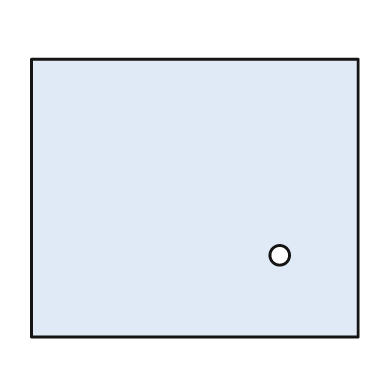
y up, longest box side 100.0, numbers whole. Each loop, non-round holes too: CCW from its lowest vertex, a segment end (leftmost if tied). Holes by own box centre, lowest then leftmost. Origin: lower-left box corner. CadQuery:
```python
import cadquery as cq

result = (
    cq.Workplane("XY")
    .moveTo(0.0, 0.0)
    .lineTo(100.0, 0.0)
    .lineTo(100.0, 85.0)
    .lineTo(0.0, 85.0)
    .close()
    .moveTo(76.0, 25.0)
    .circle(3.0)
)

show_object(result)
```